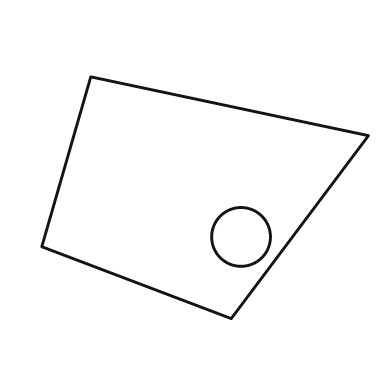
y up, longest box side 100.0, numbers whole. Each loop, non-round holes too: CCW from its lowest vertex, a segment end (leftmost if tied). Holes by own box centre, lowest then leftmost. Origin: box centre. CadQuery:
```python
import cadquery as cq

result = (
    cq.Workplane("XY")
    .moveTo(8.0, -37.0)
    .lineTo(50.0, 19.0)
    .lineTo(-35.0, 37.0)
    .lineTo(-50.0, -15.0)
    .close()
    .moveTo(11.0, -12.0)
    .circle(9.0)
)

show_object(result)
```